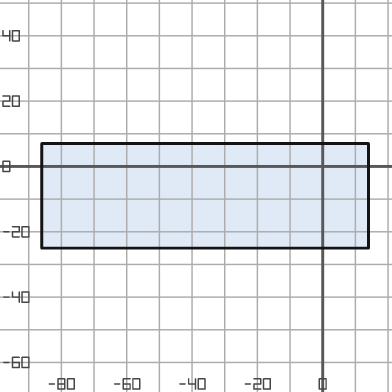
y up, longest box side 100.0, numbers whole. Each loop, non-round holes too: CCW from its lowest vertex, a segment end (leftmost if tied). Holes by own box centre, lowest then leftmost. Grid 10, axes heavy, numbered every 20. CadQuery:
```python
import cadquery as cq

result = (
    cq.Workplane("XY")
    .moveTo(-86.0, -25.0)
    .lineTo(14.0, -25.0)
    .lineTo(14.0, 7.0)
    .lineTo(-86.0, 7.0)
    .close()
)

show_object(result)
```